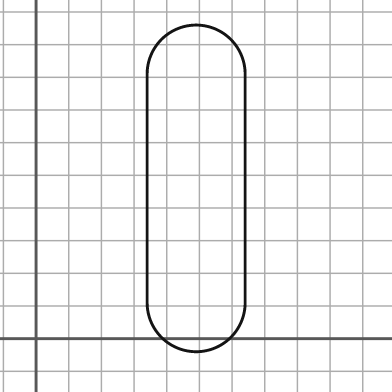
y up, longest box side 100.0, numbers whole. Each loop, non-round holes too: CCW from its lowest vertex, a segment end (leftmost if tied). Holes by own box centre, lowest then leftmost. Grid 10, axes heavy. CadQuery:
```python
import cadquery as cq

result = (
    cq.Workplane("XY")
    .moveTo(34.0, 11.0)
    .threePointArc((49.0, -4.0), (64.0, 11.0))
    .lineTo(64.0, 81.0)
    .threePointArc((49.0, 96.0), (34.0, 81.0))
    .close()
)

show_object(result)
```